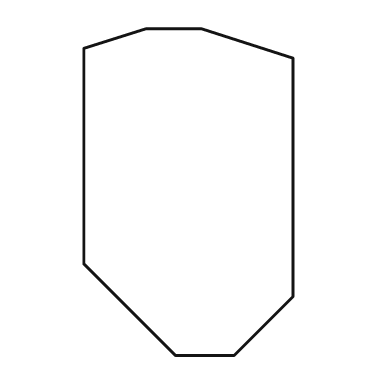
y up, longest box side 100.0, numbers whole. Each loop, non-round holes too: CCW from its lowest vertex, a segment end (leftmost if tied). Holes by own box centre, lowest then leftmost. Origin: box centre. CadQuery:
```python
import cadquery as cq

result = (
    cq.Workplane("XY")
    .moveTo(-4.0, -50.0)
    .lineTo(14.0, -50.0)
    .lineTo(32.0, -32.0)
    .lineTo(32.0, 41.0)
    .lineTo(4.0, 50.0)
    .lineTo(-13.0, 50.0)
    .lineTo(-32.0, 44.0)
    .lineTo(-32.0, -22.0)
    .close()
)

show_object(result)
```